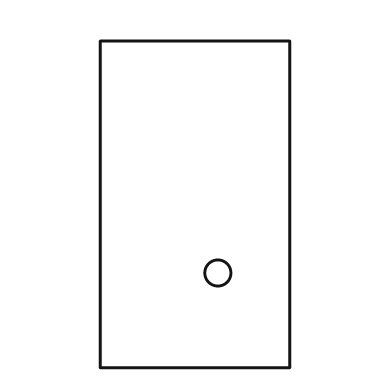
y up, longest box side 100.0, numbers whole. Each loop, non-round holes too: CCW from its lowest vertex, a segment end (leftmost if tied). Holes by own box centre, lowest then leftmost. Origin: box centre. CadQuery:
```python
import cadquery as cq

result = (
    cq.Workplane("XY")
    .moveTo(-29.0, -50.0)
    .lineTo(29.0, -50.0)
    .lineTo(29.0, 50.0)
    .lineTo(-29.0, 50.0)
    .close()
    .moveTo(7.0, -21.0)
    .circle(4.0)
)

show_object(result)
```